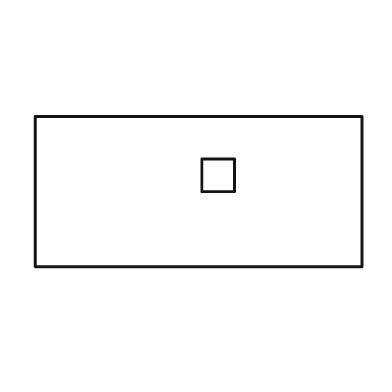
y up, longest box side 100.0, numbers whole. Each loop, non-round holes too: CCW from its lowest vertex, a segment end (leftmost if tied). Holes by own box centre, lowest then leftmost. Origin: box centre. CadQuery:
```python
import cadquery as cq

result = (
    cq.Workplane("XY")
    .moveTo(-50.0, -23.0)
    .lineTo(50.0, -23.0)
    .lineTo(50.0, 23.0)
    .lineTo(-50.0, 23.0)
    .close()
    .moveTo(1.0, 0.0)
    .lineTo(11.0, 0.0)
    .lineTo(11.0, 10.0)
    .lineTo(1.0, 10.0)
    .close()
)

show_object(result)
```